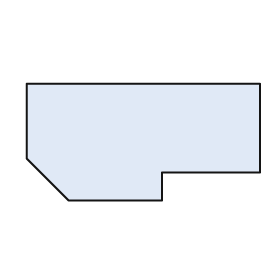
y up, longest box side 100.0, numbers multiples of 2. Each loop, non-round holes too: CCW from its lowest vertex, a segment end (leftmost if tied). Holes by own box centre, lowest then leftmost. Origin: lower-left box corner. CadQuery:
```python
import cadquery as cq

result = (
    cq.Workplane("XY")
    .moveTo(18.0, 0.0)
    .lineTo(58.0, 0.0)
    .lineTo(58.0, 12.0)
    .lineTo(100.0, 12.0)
    .lineTo(100.0, 50.0)
    .lineTo(0.0, 50.0)
    .lineTo(0.0, 18.0)
    .close()
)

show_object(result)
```